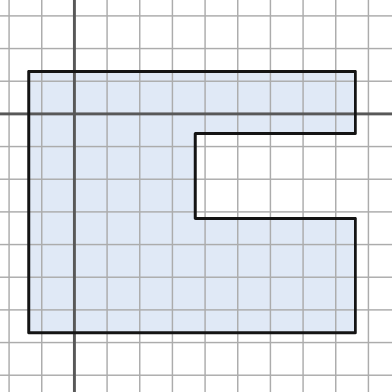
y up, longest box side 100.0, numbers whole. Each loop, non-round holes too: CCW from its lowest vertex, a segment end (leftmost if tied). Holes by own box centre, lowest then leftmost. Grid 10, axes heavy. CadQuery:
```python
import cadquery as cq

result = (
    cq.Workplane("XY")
    .moveTo(-14.0, -67.0)
    .lineTo(86.0, -67.0)
    .lineTo(86.0, -32.0)
    .lineTo(37.0, -32.0)
    .lineTo(37.0, -6.0)
    .lineTo(86.0, -6.0)
    .lineTo(86.0, 13.0)
    .lineTo(-14.0, 13.0)
    .close()
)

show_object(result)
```